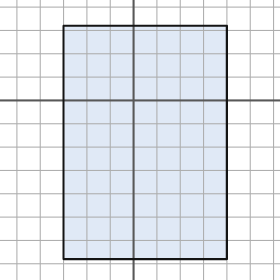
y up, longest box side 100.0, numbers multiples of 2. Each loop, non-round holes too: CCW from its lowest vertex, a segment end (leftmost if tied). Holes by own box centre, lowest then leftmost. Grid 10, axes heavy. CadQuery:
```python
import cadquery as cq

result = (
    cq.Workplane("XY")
    .moveTo(-30.0, -68.0)
    .lineTo(40.0, -68.0)
    .lineTo(40.0, 32.0)
    .lineTo(-30.0, 32.0)
    .close()
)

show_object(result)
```